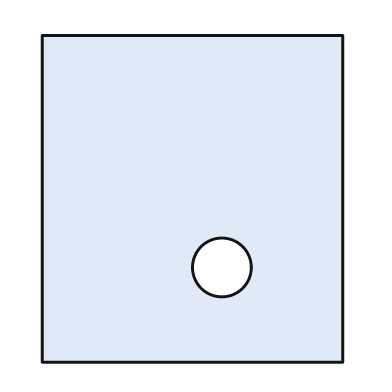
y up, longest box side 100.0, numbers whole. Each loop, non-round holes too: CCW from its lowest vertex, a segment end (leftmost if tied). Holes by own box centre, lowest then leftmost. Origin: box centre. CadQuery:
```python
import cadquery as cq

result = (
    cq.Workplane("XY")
    .moveTo(-46.0, -50.0)
    .lineTo(46.0, -50.0)
    .lineTo(46.0, 50.0)
    .lineTo(-46.0, 50.0)
    .close()
    .moveTo(9.0, -21.0)
    .circle(9.0)
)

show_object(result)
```